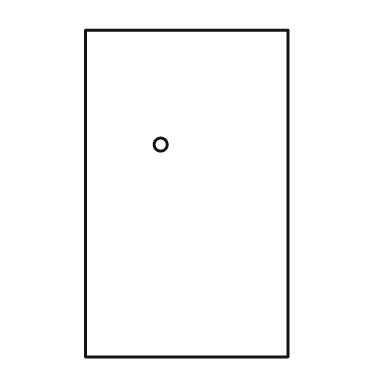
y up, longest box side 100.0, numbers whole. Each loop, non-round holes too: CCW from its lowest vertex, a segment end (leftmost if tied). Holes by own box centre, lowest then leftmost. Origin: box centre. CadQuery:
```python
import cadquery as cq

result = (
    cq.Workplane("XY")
    .moveTo(-31.0, -50.0)
    .lineTo(31.0, -50.0)
    .lineTo(31.0, 50.0)
    .lineTo(-31.0, 50.0)
    .close()
    .moveTo(-8.0, 15.0)
    .circle(2.0)
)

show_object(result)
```